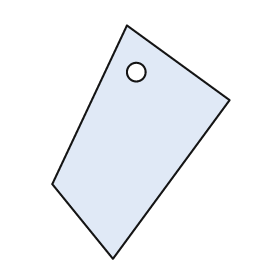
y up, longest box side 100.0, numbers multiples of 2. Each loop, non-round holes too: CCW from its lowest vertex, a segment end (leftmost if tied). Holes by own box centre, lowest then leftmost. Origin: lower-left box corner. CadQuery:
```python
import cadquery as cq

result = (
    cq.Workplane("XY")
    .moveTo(26.0, 0.0)
    .lineTo(76.0, 68.0)
    .lineTo(32.0, 100.0)
    .lineTo(0.0, 32.0)
    .close()
    .moveTo(36.0, 80.0)
    .circle(4.0)
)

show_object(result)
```